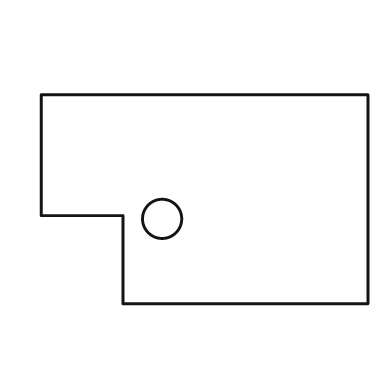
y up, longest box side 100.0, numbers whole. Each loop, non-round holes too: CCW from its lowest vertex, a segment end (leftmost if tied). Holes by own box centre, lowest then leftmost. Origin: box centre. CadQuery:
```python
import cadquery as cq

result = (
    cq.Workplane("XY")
    .moveTo(-25.0, -32.0)
    .lineTo(50.0, -32.0)
    .lineTo(50.0, 32.0)
    .lineTo(-50.0, 32.0)
    .lineTo(-50.0, -5.0)
    .lineTo(-25.0, -5.0)
    .close()
    .moveTo(-13.0, -6.0)
    .circle(6.0)
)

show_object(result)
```